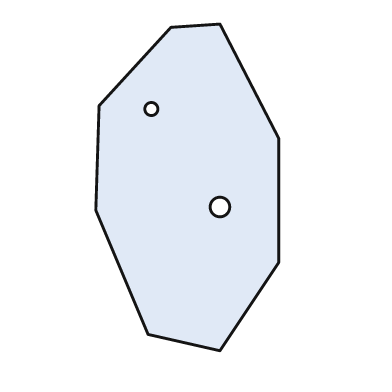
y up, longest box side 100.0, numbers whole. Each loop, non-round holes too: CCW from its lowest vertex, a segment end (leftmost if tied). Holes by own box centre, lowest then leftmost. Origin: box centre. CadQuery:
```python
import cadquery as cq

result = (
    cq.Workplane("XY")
    .moveTo(10.0, -50.0)
    .lineTo(28.0, -23.0)
    .lineTo(28.0, 15.0)
    .lineTo(10.0, 50.0)
    .lineTo(-5.0, 49.0)
    .lineTo(-27.0, 25.0)
    .lineTo(-28.0, -7.0)
    .lineTo(-12.0, -45.0)
    .close()
    .moveTo(10.0, -6.0)
    .circle(3.0)
    .moveTo(-11.0, 24.0)
    .circle(2.0)
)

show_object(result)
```